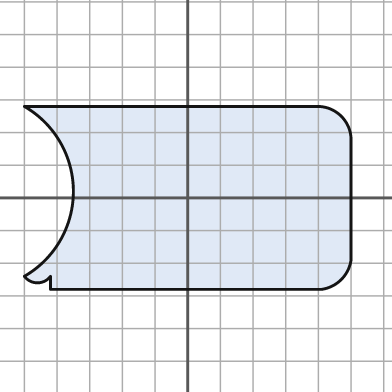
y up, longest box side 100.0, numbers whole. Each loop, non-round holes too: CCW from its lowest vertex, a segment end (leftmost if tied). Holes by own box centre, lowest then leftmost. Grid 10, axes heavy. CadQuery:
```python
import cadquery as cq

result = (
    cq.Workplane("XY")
    .moveTo(-42.0, -28.0)
    .lineTo(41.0, -28.0)
    .threePointArc((47.0, -25.0), (50.0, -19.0))
    .lineTo(50.0, 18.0)
    .threePointArc((47.0, 25.0), (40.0, 28.0))
    .lineTo(-50.0, 28.0)
    .threePointArc((-35.0, 2.0), (-50.0, -24.0))
    .threePointArc((-46.0, -26.0), (-42.0, -24.0))
    .close()
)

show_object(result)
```